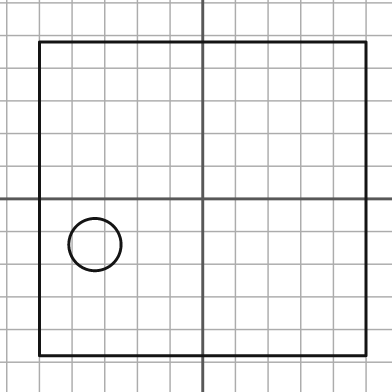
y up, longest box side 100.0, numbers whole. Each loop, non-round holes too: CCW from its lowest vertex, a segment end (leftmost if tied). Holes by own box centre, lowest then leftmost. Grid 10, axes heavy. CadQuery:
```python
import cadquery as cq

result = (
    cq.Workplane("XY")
    .moveTo(-50.0, -48.0)
    .lineTo(50.0, -48.0)
    .lineTo(50.0, 48.0)
    .lineTo(-50.0, 48.0)
    .close()
    .moveTo(-33.0, -14.0)
    .circle(8.0)
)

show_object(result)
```